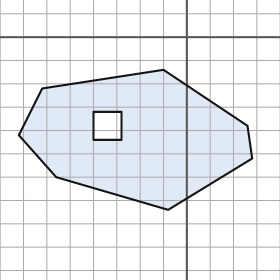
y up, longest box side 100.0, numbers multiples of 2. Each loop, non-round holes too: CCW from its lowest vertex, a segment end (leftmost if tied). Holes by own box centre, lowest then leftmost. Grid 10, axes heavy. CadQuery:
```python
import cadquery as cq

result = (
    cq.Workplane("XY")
    .moveTo(-8.0, -74.0)
    .lineTo(28.0, -52.0)
    .lineTo(26.0, -38.0)
    .lineTo(-10.0, -14.0)
    .lineTo(-62.0, -22.0)
    .lineTo(-72.0, -42.0)
    .lineTo(-56.0, -60.0)
    .close()
    .moveTo(-40.0, -44.0)
    .lineTo(-28.0, -44.0)
    .lineTo(-28.0, -32.0)
    .lineTo(-40.0, -32.0)
    .close()
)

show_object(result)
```